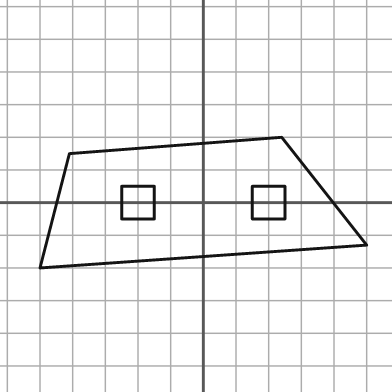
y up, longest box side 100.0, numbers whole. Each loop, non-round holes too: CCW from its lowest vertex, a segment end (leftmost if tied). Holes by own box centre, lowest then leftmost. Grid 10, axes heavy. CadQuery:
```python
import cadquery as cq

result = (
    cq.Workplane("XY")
    .moveTo(-50.0, -20.0)
    .lineTo(50.0, -13.0)
    .lineTo(24.0, 20.0)
    .lineTo(-41.0, 15.0)
    .close()
    .moveTo(-25.0, -5.0)
    .lineTo(-15.0, -5.0)
    .lineTo(-15.0, 5.0)
    .lineTo(-25.0, 5.0)
    .close()
    .moveTo(15.0, -5.0)
    .lineTo(25.0, -5.0)
    .lineTo(25.0, 5.0)
    .lineTo(15.0, 5.0)
    .close()
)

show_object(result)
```